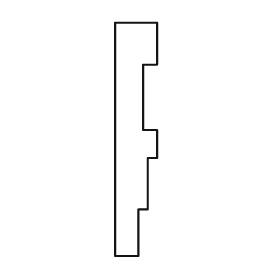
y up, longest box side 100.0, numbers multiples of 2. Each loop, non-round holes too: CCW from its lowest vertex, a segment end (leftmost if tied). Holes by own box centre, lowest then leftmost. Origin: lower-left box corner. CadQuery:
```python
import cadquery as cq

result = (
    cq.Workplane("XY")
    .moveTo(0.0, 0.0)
    .lineTo(10.0, 0.0)
    .lineTo(10.0, 20.0)
    .lineTo(14.0, 20.0)
    .lineTo(14.0, 42.0)
    .lineTo(18.0, 42.0)
    .lineTo(18.0, 54.0)
    .lineTo(12.0, 54.0)
    .lineTo(12.0, 82.0)
    .lineTo(18.0, 82.0)
    .lineTo(18.0, 100.0)
    .lineTo(0.0, 100.0)
    .close()
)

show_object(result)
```